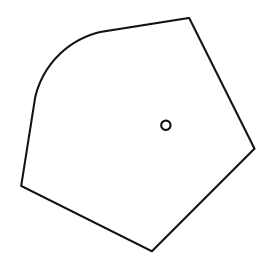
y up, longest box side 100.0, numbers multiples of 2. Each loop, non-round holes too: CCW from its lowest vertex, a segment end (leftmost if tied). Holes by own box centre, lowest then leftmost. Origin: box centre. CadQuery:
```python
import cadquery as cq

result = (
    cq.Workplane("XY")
    .moveTo(6.0, -50.0)
    .lineTo(50.0, -6.0)
    .lineTo(22.0, 50.0)
    .lineTo(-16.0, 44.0)
    .threePointArc((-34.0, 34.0), (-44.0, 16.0))
    .lineTo(-50.0, -22.0)
    .close()
    .moveTo(12.0, 4.0)
    .circle(2.0)
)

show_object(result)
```